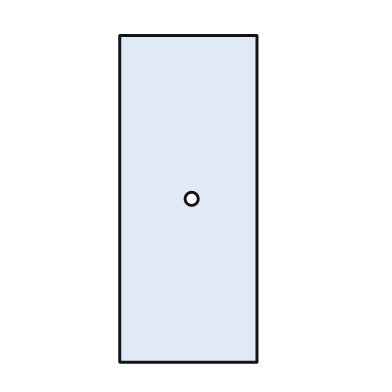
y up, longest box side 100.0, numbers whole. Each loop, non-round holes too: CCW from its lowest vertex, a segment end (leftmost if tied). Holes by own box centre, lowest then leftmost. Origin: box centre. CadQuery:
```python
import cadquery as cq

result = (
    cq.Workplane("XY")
    .moveTo(-21.0, -50.0)
    .lineTo(21.0, -50.0)
    .lineTo(21.0, 50.0)
    .lineTo(-21.0, 50.0)
    .close()
    .moveTo(1.0, 0.0)
    .circle(2.0)
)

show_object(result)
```